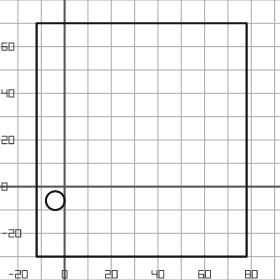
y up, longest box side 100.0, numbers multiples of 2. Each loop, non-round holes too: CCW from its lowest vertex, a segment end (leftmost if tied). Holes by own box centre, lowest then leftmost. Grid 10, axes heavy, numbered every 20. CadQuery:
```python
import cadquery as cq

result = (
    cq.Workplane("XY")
    .moveTo(-12.0, -30.0)
    .lineTo(78.0, -30.0)
    .lineTo(78.0, 70.0)
    .lineTo(-12.0, 70.0)
    .close()
    .moveTo(-4.0, -6.0)
    .circle(4.0)
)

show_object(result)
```